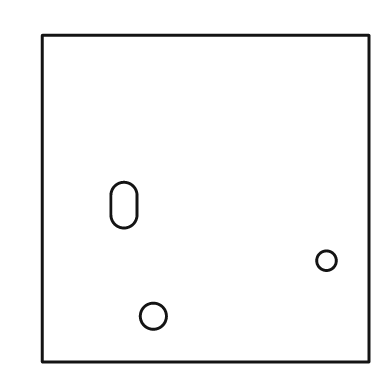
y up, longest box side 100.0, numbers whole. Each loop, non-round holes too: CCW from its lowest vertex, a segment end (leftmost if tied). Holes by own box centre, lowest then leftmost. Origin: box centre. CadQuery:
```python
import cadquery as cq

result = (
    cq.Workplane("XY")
    .moveTo(-50.0, -50.0)
    .lineTo(50.0, -50.0)
    .lineTo(50.0, 50.0)
    .lineTo(-50.0, 50.0)
    .close()
    .moveTo(-16.0, -36.0)
    .circle(4.0)
    .moveTo(37.0, -19.0)
    .circle(3.0)
    .moveTo(-29.0, -5.0)
    .threePointArc((-25.0, -9.0), (-21.0, -5.0))
    .lineTo(-21.0, 1.0)
    .threePointArc((-25.0, 5.0), (-29.0, 1.0))
    .close()
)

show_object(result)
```